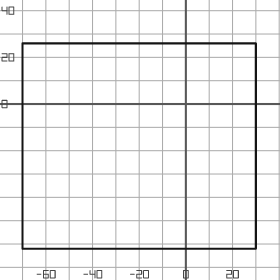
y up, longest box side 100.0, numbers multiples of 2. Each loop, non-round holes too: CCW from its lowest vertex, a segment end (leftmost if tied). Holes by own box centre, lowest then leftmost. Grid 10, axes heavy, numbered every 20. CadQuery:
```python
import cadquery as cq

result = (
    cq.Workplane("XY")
    .moveTo(-70.0, -62.0)
    .lineTo(30.0, -62.0)
    .lineTo(30.0, 26.0)
    .lineTo(-70.0, 26.0)
    .close()
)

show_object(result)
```